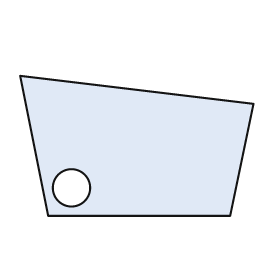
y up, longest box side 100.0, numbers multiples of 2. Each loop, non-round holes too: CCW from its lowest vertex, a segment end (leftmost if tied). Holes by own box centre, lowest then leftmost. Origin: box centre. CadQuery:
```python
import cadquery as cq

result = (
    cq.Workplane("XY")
    .moveTo(-38.0, -30.0)
    .lineTo(40.0, -30.0)
    .lineTo(50.0, 18.0)
    .lineTo(-50.0, 30.0)
    .close()
    .moveTo(-28.0, -18.0)
    .circle(8.0)
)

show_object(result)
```